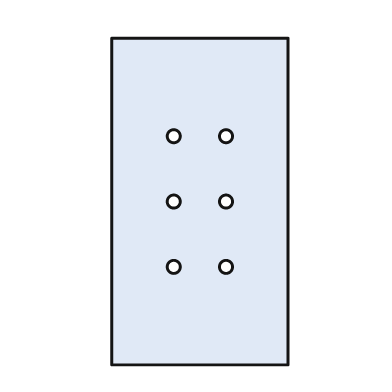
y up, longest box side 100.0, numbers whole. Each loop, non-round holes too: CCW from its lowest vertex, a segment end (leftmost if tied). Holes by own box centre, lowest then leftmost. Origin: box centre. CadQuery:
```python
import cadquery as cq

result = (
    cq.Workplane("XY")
    .moveTo(-27.0, -50.0)
    .lineTo(27.0, -50.0)
    .lineTo(27.0, 50.0)
    .lineTo(-27.0, 50.0)
    .close()
    .moveTo(-8.0, -20.0)
    .circle(2.0)
    .moveTo(8.0, -20.0)
    .circle(2.0)
    .moveTo(-8.0, 0.0)
    .circle(2.0)
    .moveTo(8.0, 0.0)
    .circle(2.0)
    .moveTo(-8.0, 20.0)
    .circle(2.0)
    .moveTo(8.0, 20.0)
    .circle(2.0)
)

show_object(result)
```